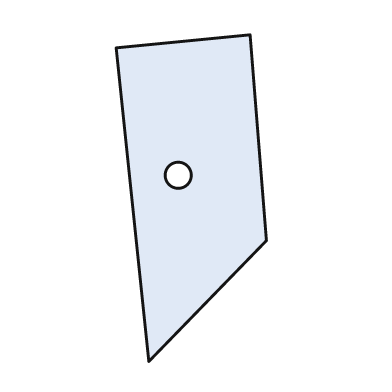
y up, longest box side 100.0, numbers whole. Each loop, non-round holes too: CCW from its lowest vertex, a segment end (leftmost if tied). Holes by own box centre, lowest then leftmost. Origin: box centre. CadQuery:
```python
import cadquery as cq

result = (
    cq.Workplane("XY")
    .moveTo(-13.0, -50.0)
    .lineTo(23.0, -13.0)
    .lineTo(18.0, 50.0)
    .lineTo(-23.0, 46.0)
    .close()
    .moveTo(-4.0, 7.0)
    .circle(4.0)
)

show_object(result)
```